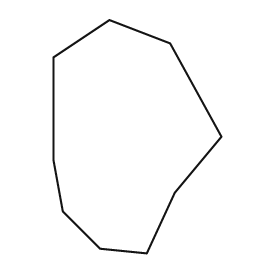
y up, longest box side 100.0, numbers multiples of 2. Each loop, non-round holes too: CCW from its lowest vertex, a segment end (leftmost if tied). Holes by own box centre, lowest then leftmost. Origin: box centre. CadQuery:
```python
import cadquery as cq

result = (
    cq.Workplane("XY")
    .moveTo(4.0, -50.0)
    .lineTo(16.0, -24.0)
    .lineTo(36.0, 0.0)
    .lineTo(14.0, 40.0)
    .lineTo(-12.0, 50.0)
    .lineTo(-36.0, 34.0)
    .lineTo(-36.0, -10.0)
    .lineTo(-32.0, -32.0)
    .lineTo(-16.0, -48.0)
    .close()
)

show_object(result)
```